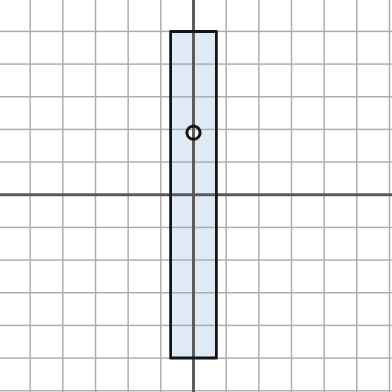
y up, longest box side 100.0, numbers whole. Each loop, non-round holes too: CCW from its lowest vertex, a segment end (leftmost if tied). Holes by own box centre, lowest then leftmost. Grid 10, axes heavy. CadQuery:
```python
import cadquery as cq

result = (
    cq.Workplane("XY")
    .moveTo(-7.0, -50.0)
    .lineTo(7.0, -50.0)
    .lineTo(7.0, 50.0)
    .lineTo(-7.0, 50.0)
    .close()
    .moveTo(0.0, 19.0)
    .circle(2.0)
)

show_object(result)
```